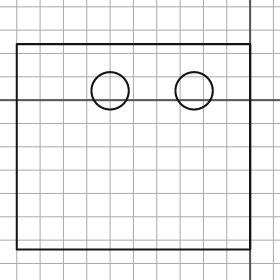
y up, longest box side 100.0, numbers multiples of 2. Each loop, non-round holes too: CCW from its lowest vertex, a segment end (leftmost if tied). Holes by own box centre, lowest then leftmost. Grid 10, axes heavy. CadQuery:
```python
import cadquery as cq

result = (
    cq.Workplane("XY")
    .moveTo(-100.0, -64.0)
    .lineTo(0.0, -64.0)
    .lineTo(0.0, 24.0)
    .lineTo(-100.0, 24.0)
    .close()
    .moveTo(-60.0, 4.0)
    .circle(8.0)
    .moveTo(-24.0, 4.0)
    .circle(8.0)
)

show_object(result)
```